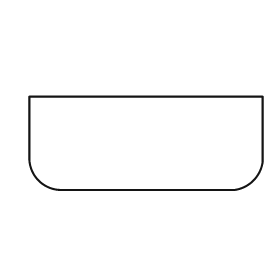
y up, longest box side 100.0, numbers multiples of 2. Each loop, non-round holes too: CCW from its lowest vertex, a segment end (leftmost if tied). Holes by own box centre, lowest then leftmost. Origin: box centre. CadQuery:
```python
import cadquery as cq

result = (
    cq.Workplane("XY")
    .moveTo(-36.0, -20.0)
    .lineTo(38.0, -20.0)
    .threePointArc((46.0, -16.0), (50.0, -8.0))
    .lineTo(50.0, 20.0)
    .lineTo(-50.0, 20.0)
    .lineTo(-50.0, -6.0)
    .threePointArc((-46.0, -16.0), (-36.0, -20.0))
    .close()
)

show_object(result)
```